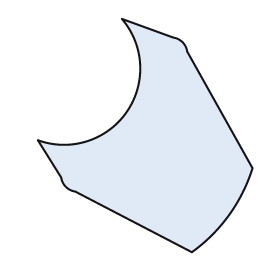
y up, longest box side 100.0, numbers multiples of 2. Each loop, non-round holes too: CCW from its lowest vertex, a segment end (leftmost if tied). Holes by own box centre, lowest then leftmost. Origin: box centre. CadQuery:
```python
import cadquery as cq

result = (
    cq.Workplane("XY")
    .moveTo(20.0, -50.0)
    .threePointArc((36.0, -34.0), (46.0, -14.0))
    .lineTo(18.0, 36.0)
    .threePointArc((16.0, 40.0), (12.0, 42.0))
    .lineTo(-10.0, 50.0)
    .threePointArc((-8.0, 10.0), (-46.0, -2.0))
    .lineTo(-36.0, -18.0)
    .threePointArc((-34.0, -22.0), (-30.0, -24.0))
    .close()
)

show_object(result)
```